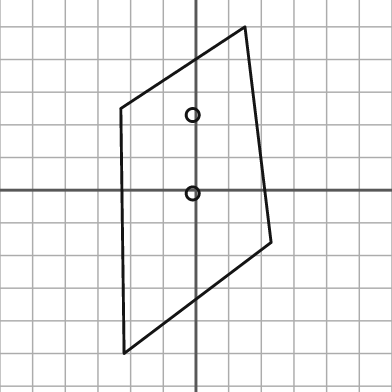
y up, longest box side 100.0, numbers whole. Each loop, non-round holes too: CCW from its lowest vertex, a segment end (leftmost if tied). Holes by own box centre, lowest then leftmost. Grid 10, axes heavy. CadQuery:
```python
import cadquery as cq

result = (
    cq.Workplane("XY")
    .moveTo(-22.0, -50.0)
    .lineTo(23.0, -16.0)
    .lineTo(15.0, 50.0)
    .lineTo(-23.0, 25.0)
    .close()
    .moveTo(-1.0, -1.0)
    .circle(2.0)
    .moveTo(-1.0, 23.0)
    .circle(2.0)
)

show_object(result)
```